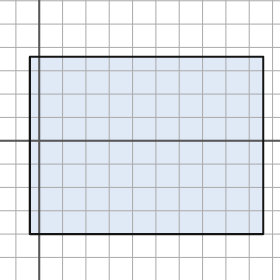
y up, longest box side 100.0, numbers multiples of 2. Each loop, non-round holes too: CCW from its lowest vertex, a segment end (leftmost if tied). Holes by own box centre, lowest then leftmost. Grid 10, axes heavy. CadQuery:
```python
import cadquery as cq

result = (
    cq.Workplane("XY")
    .moveTo(-4.0, -40.0)
    .lineTo(96.0, -40.0)
    .lineTo(96.0, 36.0)
    .lineTo(-4.0, 36.0)
    .close()
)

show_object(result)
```